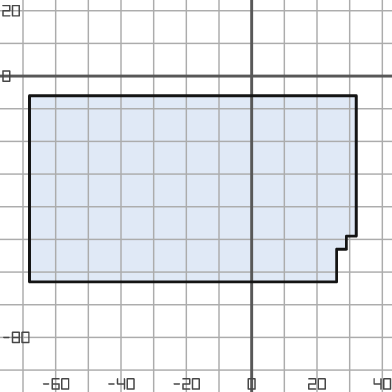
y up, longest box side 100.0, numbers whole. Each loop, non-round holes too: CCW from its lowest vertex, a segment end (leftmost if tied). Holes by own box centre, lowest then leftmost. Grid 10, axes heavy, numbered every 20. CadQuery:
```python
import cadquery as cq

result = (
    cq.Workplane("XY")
    .moveTo(-68.0, -63.0)
    .lineTo(26.0, -63.0)
    .lineTo(26.0, -53.0)
    .lineTo(29.0, -53.0)
    .lineTo(29.0, -49.0)
    .lineTo(32.0, -49.0)
    .lineTo(32.0, -6.0)
    .lineTo(-68.0, -6.0)
    .close()
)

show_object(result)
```